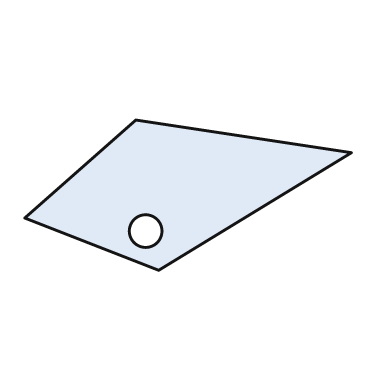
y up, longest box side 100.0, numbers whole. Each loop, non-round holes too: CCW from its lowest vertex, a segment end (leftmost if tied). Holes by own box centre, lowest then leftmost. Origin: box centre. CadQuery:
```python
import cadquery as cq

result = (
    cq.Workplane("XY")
    .moveTo(-9.0, -23.0)
    .lineTo(50.0, 13.0)
    .lineTo(-16.0, 23.0)
    .lineTo(-50.0, -7.0)
    .close()
    .moveTo(-13.0, -11.0)
    .circle(5.0)
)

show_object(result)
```